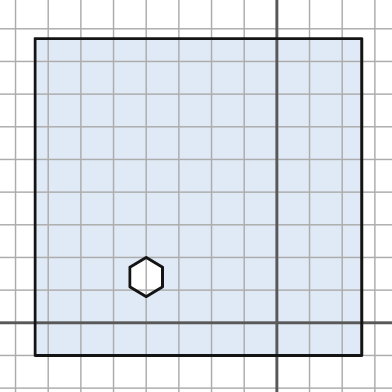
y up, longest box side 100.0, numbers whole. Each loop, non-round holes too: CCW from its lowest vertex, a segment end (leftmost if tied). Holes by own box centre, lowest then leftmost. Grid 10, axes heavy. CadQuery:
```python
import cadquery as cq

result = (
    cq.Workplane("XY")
    .moveTo(-74.0, -10.0)
    .lineTo(26.0, -10.0)
    .lineTo(26.0, 87.0)
    .lineTo(-74.0, 87.0)
    .close()
    .moveTo(-40.0, 8.0)
    .lineTo(-35.0, 11.0)
    .lineTo(-35.0, 17.0)
    .lineTo(-40.0, 20.0)
    .lineTo(-45.0, 17.0)
    .lineTo(-45.0, 11.0)
    .close()
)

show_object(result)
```